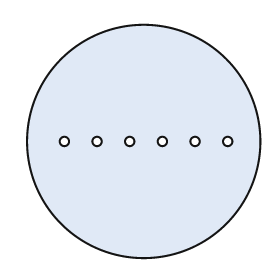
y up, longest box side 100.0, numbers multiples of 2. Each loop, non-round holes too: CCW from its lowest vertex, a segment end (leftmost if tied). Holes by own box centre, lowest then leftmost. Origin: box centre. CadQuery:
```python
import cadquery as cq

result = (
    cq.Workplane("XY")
    .moveTo(0.0, 0.0)
    .circle(50.0)
    .moveTo(-34.0, 0.0)
    .circle(2.0)
    .moveTo(-20.0, 0.0)
    .circle(2.0)
    .moveTo(-6.0, 0.0)
    .circle(2.0)
    .moveTo(8.0, 0.0)
    .circle(2.0)
    .moveTo(22.0, 0.0)
    .circle(2.0)
    .moveTo(36.0, 0.0)
    .circle(2.0)
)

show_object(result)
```